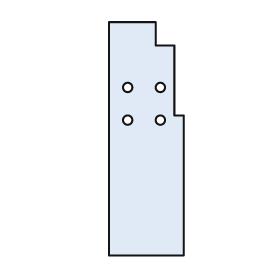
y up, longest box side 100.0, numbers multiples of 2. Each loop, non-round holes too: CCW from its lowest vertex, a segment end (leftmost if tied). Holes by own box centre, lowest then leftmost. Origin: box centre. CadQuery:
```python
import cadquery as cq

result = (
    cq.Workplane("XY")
    .moveTo(-16.0, -50.0)
    .lineTo(16.0, -50.0)
    .lineTo(16.0, 10.0)
    .lineTo(12.0, 10.0)
    .lineTo(12.0, 40.0)
    .lineTo(4.0, 40.0)
    .lineTo(4.0, 50.0)
    .lineTo(-16.0, 50.0)
    .close()
    .moveTo(-8.0, 8.0)
    .circle(2.0)
    .moveTo(6.0, 8.0)
    .circle(2.0)
    .moveTo(-8.0, 22.0)
    .circle(2.0)
    .moveTo(6.0, 22.0)
    .circle(2.0)
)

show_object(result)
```